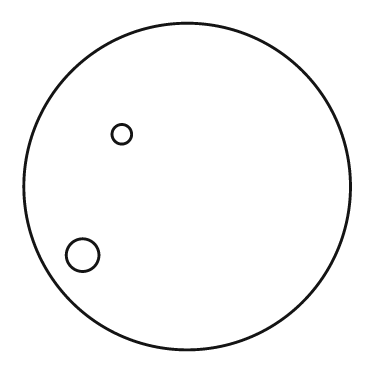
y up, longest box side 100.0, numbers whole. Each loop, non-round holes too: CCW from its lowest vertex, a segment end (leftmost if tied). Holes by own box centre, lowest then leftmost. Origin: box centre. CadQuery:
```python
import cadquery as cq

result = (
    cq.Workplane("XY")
    .moveTo(0.0, 0.0)
    .circle(50.0)
    .moveTo(-32.0, -21.0)
    .circle(5.0)
    .moveTo(-20.0, 16.0)
    .circle(3.0)
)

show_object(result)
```